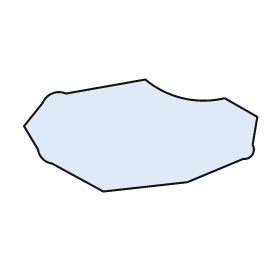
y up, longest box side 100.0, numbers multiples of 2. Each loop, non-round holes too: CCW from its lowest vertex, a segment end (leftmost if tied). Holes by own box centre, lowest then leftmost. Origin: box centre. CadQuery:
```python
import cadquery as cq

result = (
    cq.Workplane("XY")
    .moveTo(-16.0, -24.0)
    .lineTo(20.0, -20.0)
    .lineTo(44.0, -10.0)
    .threePointArc((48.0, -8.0), (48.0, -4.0))
    .lineTo(50.0, 8.0)
    .lineTo(36.0, 16.0)
    .threePointArc((18.0, 16.0), (2.0, 24.0))
    .lineTo(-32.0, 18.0)
    .threePointArc((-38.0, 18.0), (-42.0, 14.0))
    .lineTo(-50.0, 4.0)
    .lineTo(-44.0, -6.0)
    .threePointArc((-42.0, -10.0), (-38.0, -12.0))
    .close()
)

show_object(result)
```